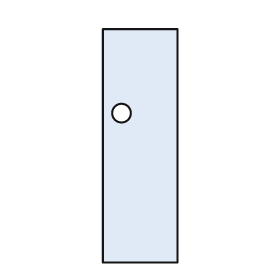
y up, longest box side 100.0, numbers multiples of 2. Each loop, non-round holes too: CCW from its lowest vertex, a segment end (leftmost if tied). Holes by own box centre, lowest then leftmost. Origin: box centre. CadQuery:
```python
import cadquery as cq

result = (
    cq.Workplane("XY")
    .moveTo(-16.0, -50.0)
    .lineTo(16.0, -50.0)
    .lineTo(16.0, 50.0)
    .lineTo(-16.0, 50.0)
    .close()
    .moveTo(-8.0, 14.0)
    .circle(4.0)
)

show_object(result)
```